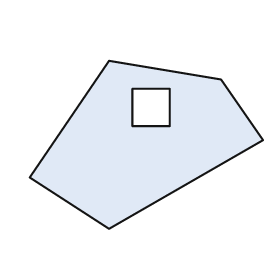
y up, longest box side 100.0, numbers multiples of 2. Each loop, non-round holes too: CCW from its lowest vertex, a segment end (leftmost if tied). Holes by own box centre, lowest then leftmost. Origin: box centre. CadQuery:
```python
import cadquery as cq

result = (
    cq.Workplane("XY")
    .moveTo(-16.0, -36.0)
    .lineTo(50.0, 2.0)
    .lineTo(32.0, 28.0)
    .lineTo(-16.0, 36.0)
    .lineTo(-50.0, -14.0)
    .close()
    .moveTo(-6.0, 8.0)
    .lineTo(10.0, 8.0)
    .lineTo(10.0, 24.0)
    .lineTo(-6.0, 24.0)
    .close()
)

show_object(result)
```